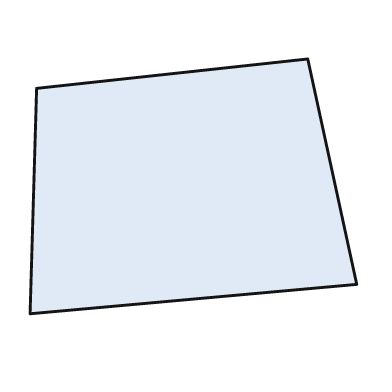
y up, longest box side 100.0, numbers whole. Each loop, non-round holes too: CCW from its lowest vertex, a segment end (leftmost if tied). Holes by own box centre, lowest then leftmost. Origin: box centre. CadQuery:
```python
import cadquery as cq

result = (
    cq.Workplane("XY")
    .moveTo(-50.0, -39.0)
    .lineTo(50.0, -30.0)
    .lineTo(35.0, 39.0)
    .lineTo(-48.0, 30.0)
    .close()
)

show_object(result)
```